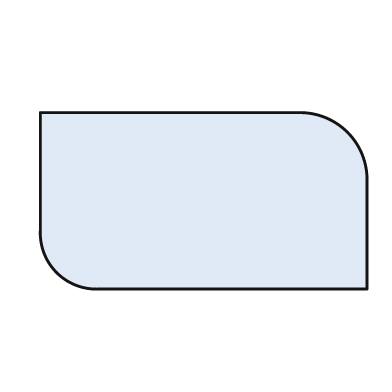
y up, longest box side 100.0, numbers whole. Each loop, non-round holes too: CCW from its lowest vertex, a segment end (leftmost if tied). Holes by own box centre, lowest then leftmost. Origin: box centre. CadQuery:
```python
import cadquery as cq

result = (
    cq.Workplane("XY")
    .moveTo(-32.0, -27.0)
    .lineTo(50.0, -27.0)
    .lineTo(50.0, 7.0)
    .threePointArc((44.0, 21.0), (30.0, 27.0))
    .lineTo(-50.0, 27.0)
    .lineTo(-50.0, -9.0)
    .threePointArc((-45.0, -22.0), (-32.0, -27.0))
    .close()
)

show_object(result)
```